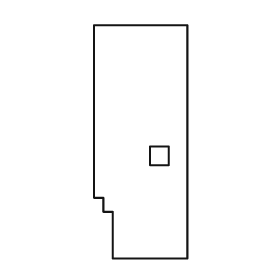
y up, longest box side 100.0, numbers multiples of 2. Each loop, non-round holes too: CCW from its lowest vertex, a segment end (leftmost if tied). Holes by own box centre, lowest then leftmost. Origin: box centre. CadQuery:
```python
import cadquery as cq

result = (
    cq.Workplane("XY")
    .moveTo(-12.0, -50.0)
    .lineTo(20.0, -50.0)
    .lineTo(20.0, 50.0)
    .lineTo(-20.0, 50.0)
    .lineTo(-20.0, -24.0)
    .lineTo(-16.0, -24.0)
    .lineTo(-16.0, -30.0)
    .lineTo(-12.0, -30.0)
    .close()
    .moveTo(4.0, -10.0)
    .lineTo(12.0, -10.0)
    .lineTo(12.0, -2.0)
    .lineTo(4.0, -2.0)
    .close()
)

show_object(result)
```